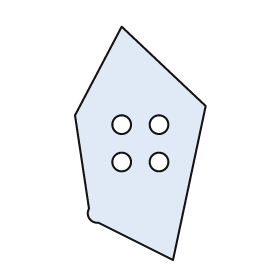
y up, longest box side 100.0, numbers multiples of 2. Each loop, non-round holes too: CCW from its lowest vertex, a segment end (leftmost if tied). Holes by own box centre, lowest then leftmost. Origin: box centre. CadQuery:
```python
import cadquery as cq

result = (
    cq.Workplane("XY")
    .moveTo(14.0, -50.0)
    .lineTo(28.0, 16.0)
    .lineTo(-8.0, 50.0)
    .lineTo(-28.0, 12.0)
    .lineTo(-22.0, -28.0)
    .threePointArc((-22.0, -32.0), (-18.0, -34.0))
    .close()
    .moveTo(-8.0, -8.0)
    .circle(4.0)
    .moveTo(8.0, -8.0)
    .circle(4.0)
    .moveTo(-8.0, 8.0)
    .circle(4.0)
    .moveTo(8.0, 8.0)
    .circle(4.0)
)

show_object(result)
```